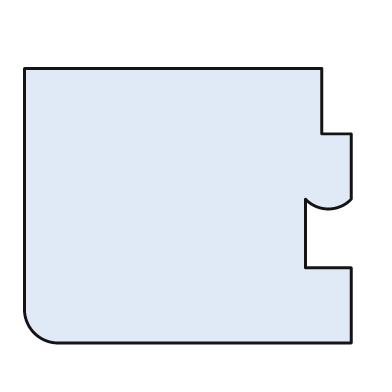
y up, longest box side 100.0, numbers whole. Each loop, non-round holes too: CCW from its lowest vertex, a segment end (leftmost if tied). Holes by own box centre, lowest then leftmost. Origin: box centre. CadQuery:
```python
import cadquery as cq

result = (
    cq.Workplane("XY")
    .moveTo(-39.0, -42.0)
    .lineTo(50.0, -42.0)
    .lineTo(50.0, -19.0)
    .lineTo(36.0, -19.0)
    .lineTo(36.0, 2.0)
    .threePointArc((43.0, -1.0), (50.0, 2.0))
    .lineTo(50.0, 22.0)
    .lineTo(41.0, 22.0)
    .lineTo(41.0, 42.0)
    .lineTo(-50.0, 42.0)
    .lineTo(-50.0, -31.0)
    .threePointArc((-47.0, -39.0), (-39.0, -42.0))
    .close()
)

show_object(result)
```